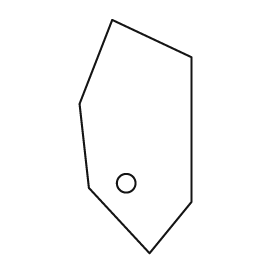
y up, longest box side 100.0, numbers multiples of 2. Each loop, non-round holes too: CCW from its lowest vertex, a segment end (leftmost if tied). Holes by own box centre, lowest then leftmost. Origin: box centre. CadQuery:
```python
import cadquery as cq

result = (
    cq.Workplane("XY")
    .moveTo(6.0, -50.0)
    .lineTo(24.0, -28.0)
    .lineTo(24.0, 34.0)
    .lineTo(-10.0, 50.0)
    .lineTo(-24.0, 14.0)
    .lineTo(-20.0, -22.0)
    .close()
    .moveTo(-4.0, -20.0)
    .circle(4.0)
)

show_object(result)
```